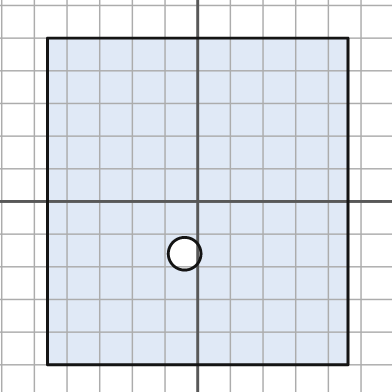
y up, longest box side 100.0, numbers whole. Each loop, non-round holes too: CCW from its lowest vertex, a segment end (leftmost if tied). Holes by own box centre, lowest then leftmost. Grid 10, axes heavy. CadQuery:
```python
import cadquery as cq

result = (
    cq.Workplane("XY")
    .moveTo(-46.0, -50.0)
    .lineTo(46.0, -50.0)
    .lineTo(46.0, 50.0)
    .lineTo(-46.0, 50.0)
    .close()
    .moveTo(-4.0, -16.0)
    .circle(5.0)
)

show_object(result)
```